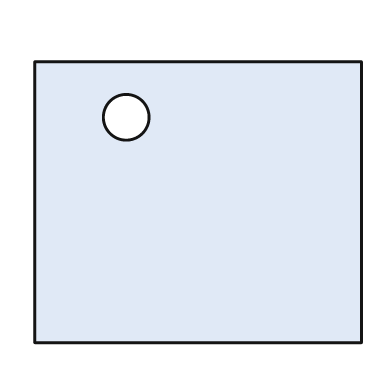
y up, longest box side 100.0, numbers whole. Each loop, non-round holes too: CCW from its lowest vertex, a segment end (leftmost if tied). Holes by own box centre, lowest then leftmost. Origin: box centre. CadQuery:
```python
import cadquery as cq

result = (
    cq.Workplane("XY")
    .moveTo(-50.0, -43.0)
    .lineTo(50.0, -43.0)
    .lineTo(50.0, 43.0)
    .lineTo(-50.0, 43.0)
    .close()
    .moveTo(-22.0, 26.0)
    .circle(7.0)
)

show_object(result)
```